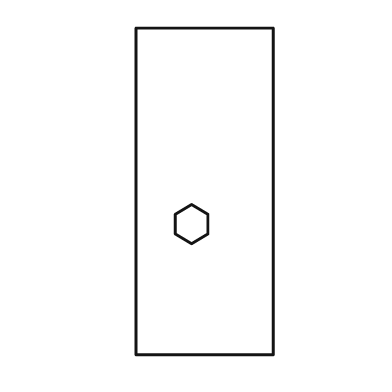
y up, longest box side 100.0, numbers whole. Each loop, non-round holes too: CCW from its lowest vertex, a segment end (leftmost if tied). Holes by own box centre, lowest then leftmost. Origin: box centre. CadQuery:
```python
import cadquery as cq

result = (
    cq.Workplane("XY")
    .moveTo(-21.0, -50.0)
    .lineTo(21.0, -50.0)
    .lineTo(21.0, 50.0)
    .lineTo(-21.0, 50.0)
    .close()
    .moveTo(-4.0, -16.0)
    .lineTo(1.0, -13.0)
    .lineTo(1.0, -7.0)
    .lineTo(-4.0, -4.0)
    .lineTo(-9.0, -7.0)
    .lineTo(-9.0, -13.0)
    .close()
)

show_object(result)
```